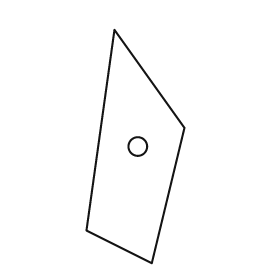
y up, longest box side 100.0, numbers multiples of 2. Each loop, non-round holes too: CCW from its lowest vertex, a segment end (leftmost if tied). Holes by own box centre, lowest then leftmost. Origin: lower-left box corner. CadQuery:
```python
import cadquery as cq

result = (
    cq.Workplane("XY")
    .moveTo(28.0, 0.0)
    .lineTo(42.0, 58.0)
    .lineTo(12.0, 100.0)
    .lineTo(0.0, 14.0)
    .close()
    .moveTo(22.0, 50.0)
    .circle(4.0)
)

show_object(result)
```